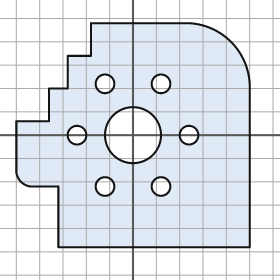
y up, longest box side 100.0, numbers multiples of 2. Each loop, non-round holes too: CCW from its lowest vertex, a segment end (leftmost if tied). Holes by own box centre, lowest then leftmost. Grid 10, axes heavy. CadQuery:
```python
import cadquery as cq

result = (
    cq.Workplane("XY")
    .moveTo(-32.0, -48.0)
    .lineTo(50.0, -48.0)
    .lineTo(50.0, 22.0)
    .threePointArc((42.0, 40.0), (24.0, 48.0))
    .lineTo(-18.0, 48.0)
    .lineTo(-18.0, 34.0)
    .lineTo(-28.0, 34.0)
    .lineTo(-28.0, 20.0)
    .lineTo(-36.0, 20.0)
    .lineTo(-36.0, 6.0)
    .lineTo(-50.0, 6.0)
    .lineTo(-50.0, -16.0)
    .threePointArc((-48.0, -20.0), (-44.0, -22.0))
    .lineTo(-32.0, -22.0)
    .close()
    .moveTo(-12.0, -22.0)
    .circle(4.0)
    .moveTo(12.0, -22.0)
    .circle(4.0)
    .moveTo(-24.0, 0.0)
    .circle(4.0)
    .moveTo(0.0, 0.0)
    .circle(12.0)
    .moveTo(24.0, 0.0)
    .circle(4.0)
    .moveTo(-12.0, 22.0)
    .circle(4.0)
    .moveTo(12.0, 22.0)
    .circle(4.0)
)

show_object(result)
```